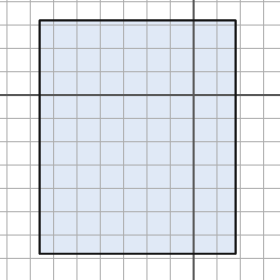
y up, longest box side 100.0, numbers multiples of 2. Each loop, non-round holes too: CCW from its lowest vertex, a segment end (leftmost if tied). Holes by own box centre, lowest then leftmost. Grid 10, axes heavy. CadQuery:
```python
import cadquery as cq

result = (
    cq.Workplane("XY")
    .moveTo(-66.0, -68.0)
    .lineTo(18.0, -68.0)
    .lineTo(18.0, 32.0)
    .lineTo(-66.0, 32.0)
    .close()
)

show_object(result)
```